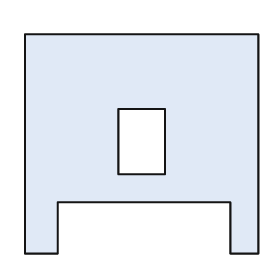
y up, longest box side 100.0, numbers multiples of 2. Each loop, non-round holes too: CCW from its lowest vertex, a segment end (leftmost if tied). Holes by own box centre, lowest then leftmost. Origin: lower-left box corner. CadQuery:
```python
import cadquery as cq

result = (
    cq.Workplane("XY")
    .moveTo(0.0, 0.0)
    .lineTo(14.0, 0.0)
    .lineTo(14.0, 22.0)
    .lineTo(88.0, 22.0)
    .lineTo(88.0, 0.0)
    .lineTo(100.0, 0.0)
    .lineTo(100.0, 94.0)
    .lineTo(0.0, 94.0)
    .close()
    .moveTo(40.0, 34.0)
    .lineTo(60.0, 34.0)
    .lineTo(60.0, 62.0)
    .lineTo(40.0, 62.0)
    .close()
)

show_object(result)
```